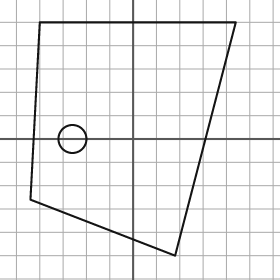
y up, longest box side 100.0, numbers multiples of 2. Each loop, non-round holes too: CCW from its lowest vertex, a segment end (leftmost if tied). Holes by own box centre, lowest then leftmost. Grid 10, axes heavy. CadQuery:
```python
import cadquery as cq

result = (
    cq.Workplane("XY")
    .moveTo(18.0, -50.0)
    .lineTo(44.0, 50.0)
    .lineTo(-40.0, 50.0)
    .lineTo(-44.0, -26.0)
    .close()
    .moveTo(-26.0, 0.0)
    .circle(6.0)
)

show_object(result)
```